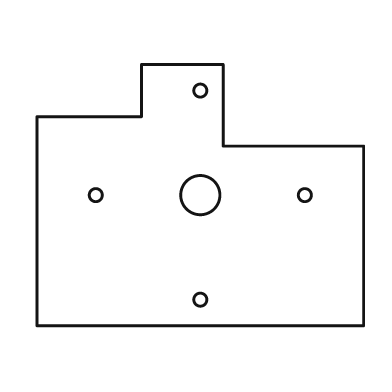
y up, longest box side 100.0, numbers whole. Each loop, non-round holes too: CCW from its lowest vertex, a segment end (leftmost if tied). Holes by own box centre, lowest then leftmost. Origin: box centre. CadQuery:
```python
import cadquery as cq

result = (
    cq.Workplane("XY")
    .moveTo(-50.0, -40.0)
    .lineTo(50.0, -40.0)
    .lineTo(50.0, 15.0)
    .lineTo(7.0, 15.0)
    .lineTo(7.0, 40.0)
    .lineTo(-18.0, 40.0)
    .lineTo(-18.0, 24.0)
    .lineTo(-50.0, 24.0)
    .close()
    .moveTo(0.0, -32.0)
    .circle(2.0)
    .moveTo(-32.0, 0.0)
    .circle(2.0)
    .moveTo(0.0, 0.0)
    .circle(6.0)
    .moveTo(32.0, 0.0)
    .circle(2.0)
    .moveTo(0.0, 32.0)
    .circle(2.0)
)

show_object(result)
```